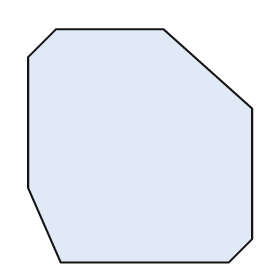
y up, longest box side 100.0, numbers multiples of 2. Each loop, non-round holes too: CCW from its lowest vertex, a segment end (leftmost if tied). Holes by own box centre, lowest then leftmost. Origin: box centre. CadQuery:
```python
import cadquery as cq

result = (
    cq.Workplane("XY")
    .moveTo(-34.0, -50.0)
    .lineTo(38.0, -50.0)
    .lineTo(48.0, -40.0)
    .lineTo(48.0, 16.0)
    .lineTo(10.0, 50.0)
    .lineTo(-36.0, 50.0)
    .lineTo(-48.0, 38.0)
    .lineTo(-48.0, -18.0)
    .close()
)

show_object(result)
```